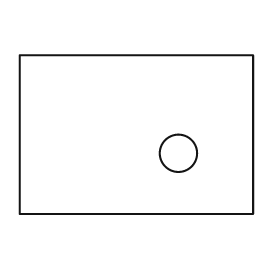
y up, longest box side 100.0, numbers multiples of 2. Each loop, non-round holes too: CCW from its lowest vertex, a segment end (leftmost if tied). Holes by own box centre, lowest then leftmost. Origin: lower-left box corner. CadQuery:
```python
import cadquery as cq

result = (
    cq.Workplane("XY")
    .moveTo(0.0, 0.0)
    .lineTo(100.0, 0.0)
    .lineTo(100.0, 68.0)
    .lineTo(0.0, 68.0)
    .close()
    .moveTo(68.0, 26.0)
    .circle(8.0)
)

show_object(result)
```